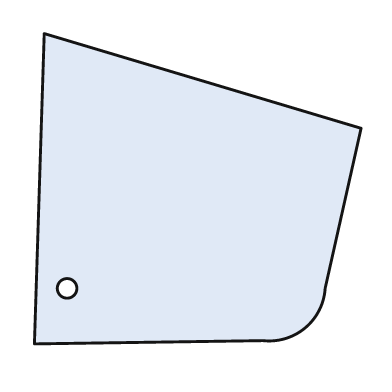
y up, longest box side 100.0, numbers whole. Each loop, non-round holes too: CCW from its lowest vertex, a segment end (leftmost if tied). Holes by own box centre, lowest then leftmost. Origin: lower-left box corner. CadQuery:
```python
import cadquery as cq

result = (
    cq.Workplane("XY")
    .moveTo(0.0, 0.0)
    .lineTo(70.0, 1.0)
    .threePointArc((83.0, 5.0), (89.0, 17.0))
    .lineTo(100.0, 66.0)
    .lineTo(3.0, 95.0)
    .close()
    .moveTo(10.0, 17.0)
    .circle(3.0)
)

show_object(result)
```